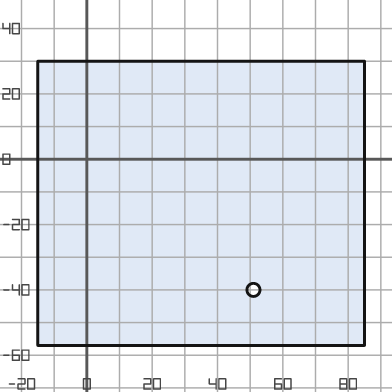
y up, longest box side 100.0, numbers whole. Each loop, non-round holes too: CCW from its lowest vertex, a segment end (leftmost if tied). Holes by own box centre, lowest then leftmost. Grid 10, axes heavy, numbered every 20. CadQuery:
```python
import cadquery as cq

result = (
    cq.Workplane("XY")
    .moveTo(-15.0, -57.0)
    .lineTo(85.0, -57.0)
    .lineTo(85.0, 30.0)
    .lineTo(-15.0, 30.0)
    .close()
    .moveTo(51.0, -40.0)
    .circle(2.0)
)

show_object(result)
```